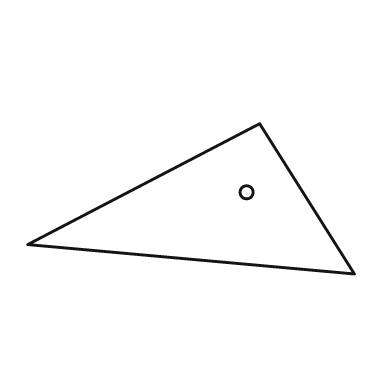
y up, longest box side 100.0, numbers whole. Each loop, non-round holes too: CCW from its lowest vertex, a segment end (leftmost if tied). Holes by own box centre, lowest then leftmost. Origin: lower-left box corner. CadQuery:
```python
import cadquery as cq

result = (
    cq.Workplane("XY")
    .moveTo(100.0, 0.0)
    .lineTo(71.0, 46.0)
    .lineTo(0.0, 9.0)
    .close()
    .moveTo(67.0, 25.0)
    .circle(2.0)
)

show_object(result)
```